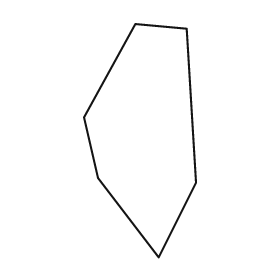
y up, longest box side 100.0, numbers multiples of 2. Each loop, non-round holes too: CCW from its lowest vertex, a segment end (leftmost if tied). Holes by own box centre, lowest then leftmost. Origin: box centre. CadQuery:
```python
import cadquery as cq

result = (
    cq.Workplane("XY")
    .moveTo(8.0, -50.0)
    .lineTo(24.0, -18.0)
    .lineTo(20.0, 48.0)
    .lineTo(-2.0, 50.0)
    .lineTo(-24.0, 10.0)
    .lineTo(-18.0, -16.0)
    .close()
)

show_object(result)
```